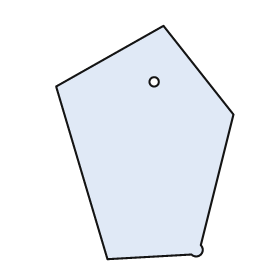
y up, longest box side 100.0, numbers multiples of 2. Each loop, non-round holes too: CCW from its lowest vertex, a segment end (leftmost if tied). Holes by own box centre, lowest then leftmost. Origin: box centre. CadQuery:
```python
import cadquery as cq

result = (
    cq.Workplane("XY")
    .moveTo(-16.0, -50.0)
    .lineTo(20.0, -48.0)
    .threePointArc((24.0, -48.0), (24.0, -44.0))
    .lineTo(38.0, 12.0)
    .lineTo(8.0, 50.0)
    .lineTo(-38.0, 24.0)
    .close()
    .moveTo(4.0, 26.0)
    .circle(2.0)
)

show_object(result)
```